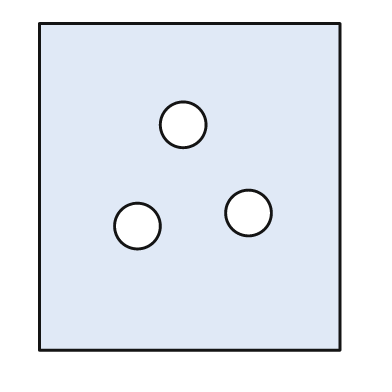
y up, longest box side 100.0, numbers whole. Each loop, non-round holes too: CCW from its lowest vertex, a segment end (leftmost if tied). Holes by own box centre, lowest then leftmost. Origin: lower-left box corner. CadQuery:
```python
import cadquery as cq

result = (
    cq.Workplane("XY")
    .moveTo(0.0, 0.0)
    .lineTo(92.0, 0.0)
    .lineTo(92.0, 100.0)
    .lineTo(0.0, 100.0)
    .close()
    .moveTo(30.0, 38.0)
    .circle(7.0)
    .moveTo(64.0, 42.0)
    .circle(7.0)
    .moveTo(44.0, 69.0)
    .circle(7.0)
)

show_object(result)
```